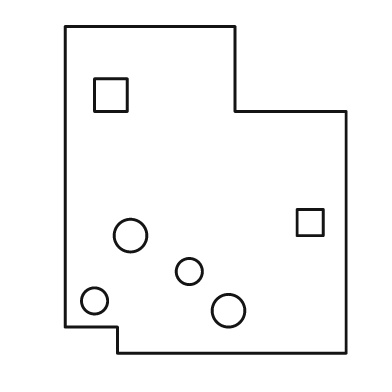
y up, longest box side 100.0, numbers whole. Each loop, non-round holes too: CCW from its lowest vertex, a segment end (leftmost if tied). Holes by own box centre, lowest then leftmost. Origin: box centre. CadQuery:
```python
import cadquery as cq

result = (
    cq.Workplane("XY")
    .moveTo(-27.0, -50.0)
    .lineTo(43.0, -50.0)
    .lineTo(43.0, 24.0)
    .lineTo(9.0, 24.0)
    .lineTo(9.0, 50.0)
    .lineTo(-43.0, 50.0)
    .lineTo(-43.0, -42.0)
    .lineTo(-27.0, -42.0)
    .close()
    .moveTo(7.0, -37.0)
    .circle(5.0)
    .moveTo(-34.0, -34.0)
    .circle(4.0)
    .moveTo(-5.0, -25.0)
    .circle(4.0)
    .moveTo(-23.0, -14.0)
    .circle(5.0)
    .moveTo(28.0, -14.0)
    .lineTo(36.0, -14.0)
    .lineTo(36.0, -6.0)
    .lineTo(28.0, -6.0)
    .close()
    .moveTo(-34.0, 24.0)
    .lineTo(-24.0, 24.0)
    .lineTo(-24.0, 34.0)
    .lineTo(-34.0, 34.0)
    .close()
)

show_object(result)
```